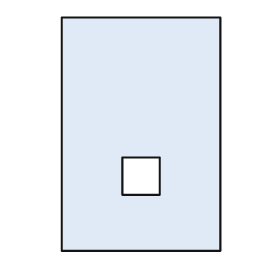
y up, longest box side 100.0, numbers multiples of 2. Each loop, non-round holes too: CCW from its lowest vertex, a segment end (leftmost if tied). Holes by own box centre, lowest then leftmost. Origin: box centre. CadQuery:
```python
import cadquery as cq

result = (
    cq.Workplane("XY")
    .moveTo(-34.0, -50.0)
    .lineTo(34.0, -50.0)
    .lineTo(34.0, 50.0)
    .lineTo(-34.0, 50.0)
    .close()
    .moveTo(-8.0, -26.0)
    .lineTo(8.0, -26.0)
    .lineTo(8.0, -10.0)
    .lineTo(-8.0, -10.0)
    .close()
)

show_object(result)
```